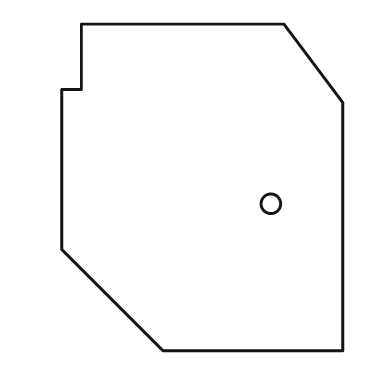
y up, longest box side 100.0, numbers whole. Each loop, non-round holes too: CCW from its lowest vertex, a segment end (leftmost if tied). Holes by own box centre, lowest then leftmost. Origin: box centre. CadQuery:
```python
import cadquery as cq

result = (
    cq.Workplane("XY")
    .moveTo(-12.0, -50.0)
    .lineTo(43.0, -50.0)
    .lineTo(43.0, 26.0)
    .lineTo(25.0, 50.0)
    .lineTo(-37.0, 50.0)
    .lineTo(-37.0, 30.0)
    .lineTo(-43.0, 30.0)
    .lineTo(-43.0, -19.0)
    .close()
    .moveTo(21.0, -5.0)
    .circle(3.0)
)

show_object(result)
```